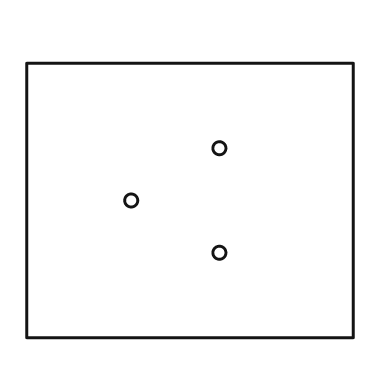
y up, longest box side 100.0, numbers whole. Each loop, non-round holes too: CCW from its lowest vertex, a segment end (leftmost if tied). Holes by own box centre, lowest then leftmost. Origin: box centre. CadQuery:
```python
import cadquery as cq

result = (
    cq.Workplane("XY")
    .moveTo(-50.0, -42.0)
    .lineTo(50.0, -42.0)
    .lineTo(50.0, 42.0)
    .lineTo(-50.0, 42.0)
    .close()
    .moveTo(9.0, -16.0)
    .circle(2.0)
    .moveTo(-18.0, 0.0)
    .circle(2.0)
    .moveTo(9.0, 16.0)
    .circle(2.0)
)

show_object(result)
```